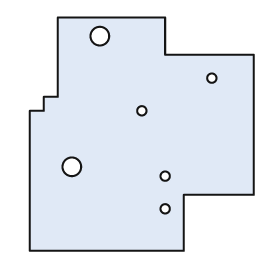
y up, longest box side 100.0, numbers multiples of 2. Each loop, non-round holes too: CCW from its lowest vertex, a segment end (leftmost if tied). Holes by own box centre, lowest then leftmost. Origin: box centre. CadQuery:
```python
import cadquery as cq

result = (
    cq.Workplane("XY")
    .moveTo(-48.0, -50.0)
    .lineTo(18.0, -50.0)
    .lineTo(18.0, -26.0)
    .lineTo(48.0, -26.0)
    .lineTo(48.0, 34.0)
    .lineTo(10.0, 34.0)
    .lineTo(10.0, 50.0)
    .lineTo(-36.0, 50.0)
    .lineTo(-36.0, 16.0)
    .lineTo(-42.0, 16.0)
    .lineTo(-42.0, 10.0)
    .lineTo(-48.0, 10.0)
    .close()
    .moveTo(10.0, -32.0)
    .circle(2.0)
    .moveTo(10.0, -18.0)
    .circle(2.0)
    .moveTo(-30.0, -14.0)
    .circle(4.0)
    .moveTo(0.0, 10.0)
    .circle(2.0)
    .moveTo(30.0, 24.0)
    .circle(2.0)
    .moveTo(-18.0, 42.0)
    .circle(4.0)
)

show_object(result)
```